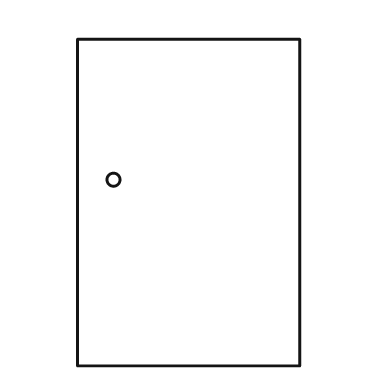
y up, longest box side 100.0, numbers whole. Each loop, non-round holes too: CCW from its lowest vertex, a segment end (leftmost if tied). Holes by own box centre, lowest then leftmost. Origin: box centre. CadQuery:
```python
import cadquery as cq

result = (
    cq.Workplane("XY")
    .moveTo(-34.0, -50.0)
    .lineTo(34.0, -50.0)
    .lineTo(34.0, 50.0)
    .lineTo(-34.0, 50.0)
    .close()
    .moveTo(-23.0, 7.0)
    .circle(2.0)
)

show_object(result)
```